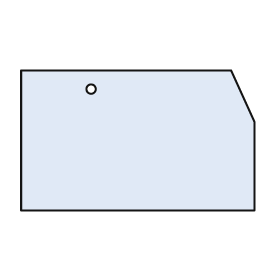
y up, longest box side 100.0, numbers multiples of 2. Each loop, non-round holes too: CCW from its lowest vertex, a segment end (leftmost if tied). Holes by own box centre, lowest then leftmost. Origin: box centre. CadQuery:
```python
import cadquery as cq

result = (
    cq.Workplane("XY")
    .moveTo(-50.0, -30.0)
    .lineTo(50.0, -30.0)
    .lineTo(50.0, 8.0)
    .lineTo(40.0, 30.0)
    .lineTo(-50.0, 30.0)
    .close()
    .moveTo(-20.0, 22.0)
    .circle(2.0)
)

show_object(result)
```